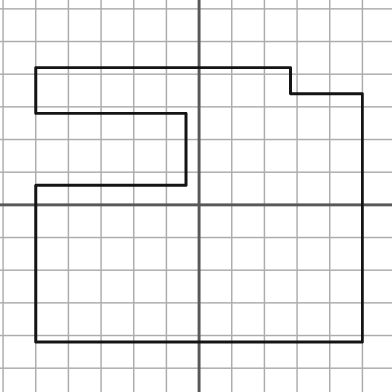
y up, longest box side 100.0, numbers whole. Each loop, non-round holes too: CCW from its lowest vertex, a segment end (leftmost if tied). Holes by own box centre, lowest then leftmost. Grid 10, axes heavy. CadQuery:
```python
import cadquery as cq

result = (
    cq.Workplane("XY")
    .moveTo(-50.0, -42.0)
    .lineTo(50.0, -42.0)
    .lineTo(50.0, 34.0)
    .lineTo(28.0, 34.0)
    .lineTo(28.0, 42.0)
    .lineTo(-50.0, 42.0)
    .lineTo(-50.0, 28.0)
    .lineTo(-4.0, 28.0)
    .lineTo(-4.0, 6.0)
    .lineTo(-50.0, 6.0)
    .close()
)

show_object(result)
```